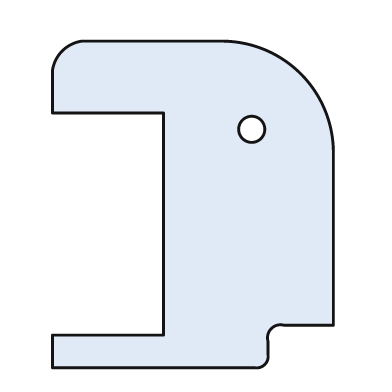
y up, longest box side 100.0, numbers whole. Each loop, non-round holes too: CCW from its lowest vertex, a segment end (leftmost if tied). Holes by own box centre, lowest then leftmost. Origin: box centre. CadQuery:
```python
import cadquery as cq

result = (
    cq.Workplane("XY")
    .moveTo(-43.0, -50.0)
    .lineTo(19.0, -50.0)
    .threePointArc((22.0, -49.0), (23.0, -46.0))
    .lineTo(23.0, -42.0)
    .threePointArc((24.0, -38.0), (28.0, -37.0))
    .lineTo(43.0, -37.0)
    .lineTo(43.0, 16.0)
    .threePointArc((33.0, 40.0), (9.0, 50.0))
    .lineTo(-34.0, 50.0)
    .threePointArc((-40.0, 47.0), (-43.0, 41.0))
    .lineTo(-43.0, 28.0)
    .lineTo(-9.0, 28.0)
    .lineTo(-9.0, -40.0)
    .lineTo(-43.0, -40.0)
    .close()
    .moveTo(18.0, 23.0)
    .circle(4.0)
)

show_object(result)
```